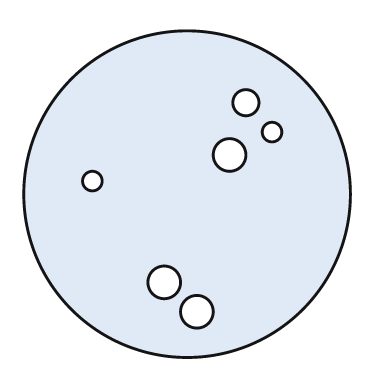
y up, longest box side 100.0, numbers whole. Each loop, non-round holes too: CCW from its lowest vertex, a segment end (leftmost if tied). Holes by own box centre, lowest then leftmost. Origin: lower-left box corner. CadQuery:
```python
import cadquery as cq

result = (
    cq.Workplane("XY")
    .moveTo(50.0, 50.0)
    .circle(50.0)
    .moveTo(53.0, 14.0)
    .circle(5.0)
    .moveTo(43.0, 23.0)
    .circle(5.0)
    .moveTo(21.0, 54.0)
    .circle(3.0)
    .moveTo(63.0, 62.0)
    .circle(5.0)
    .moveTo(76.0, 69.0)
    .circle(3.0)
    .moveTo(68.0, 78.0)
    .circle(4.0)
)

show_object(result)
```